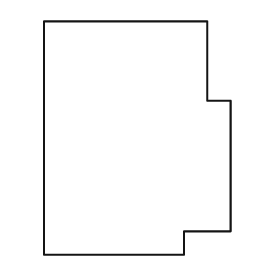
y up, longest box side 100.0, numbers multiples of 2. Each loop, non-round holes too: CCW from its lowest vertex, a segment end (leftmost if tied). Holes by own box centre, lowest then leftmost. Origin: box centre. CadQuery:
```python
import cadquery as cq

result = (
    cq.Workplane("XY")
    .moveTo(-40.0, -50.0)
    .lineTo(20.0, -50.0)
    .lineTo(20.0, -40.0)
    .lineTo(40.0, -40.0)
    .lineTo(40.0, 16.0)
    .lineTo(30.0, 16.0)
    .lineTo(30.0, 50.0)
    .lineTo(-40.0, 50.0)
    .close()
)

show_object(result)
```